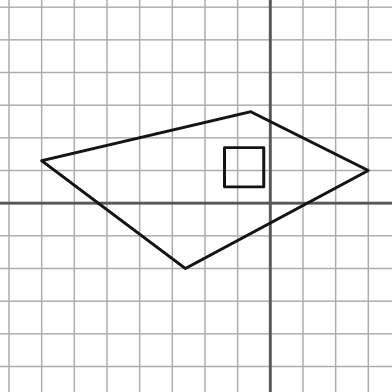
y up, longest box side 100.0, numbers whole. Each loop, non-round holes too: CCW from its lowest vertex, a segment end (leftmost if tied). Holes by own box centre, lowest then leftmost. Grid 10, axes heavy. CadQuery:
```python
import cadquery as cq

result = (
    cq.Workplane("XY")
    .moveTo(-26.0, -20.0)
    .lineTo(30.0, 10.0)
    .lineTo(-6.0, 28.0)
    .lineTo(-70.0, 13.0)
    .close()
    .moveTo(-14.0, 5.0)
    .lineTo(-2.0, 5.0)
    .lineTo(-2.0, 17.0)
    .lineTo(-14.0, 17.0)
    .close()
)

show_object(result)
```